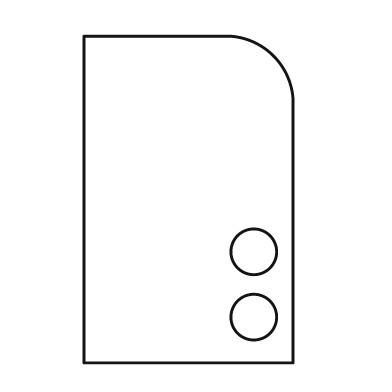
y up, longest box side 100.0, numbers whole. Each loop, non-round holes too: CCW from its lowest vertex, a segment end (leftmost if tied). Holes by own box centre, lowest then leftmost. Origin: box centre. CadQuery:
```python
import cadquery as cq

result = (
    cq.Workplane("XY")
    .moveTo(-32.0, -50.0)
    .lineTo(32.0, -50.0)
    .lineTo(32.0, 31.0)
    .threePointArc((26.0, 44.0), (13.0, 50.0))
    .lineTo(-32.0, 50.0)
    .close()
    .moveTo(20.0, -36.0)
    .circle(7.0)
    .moveTo(20.0, -16.0)
    .circle(7.0)
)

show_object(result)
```